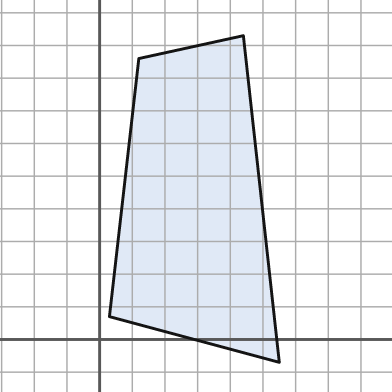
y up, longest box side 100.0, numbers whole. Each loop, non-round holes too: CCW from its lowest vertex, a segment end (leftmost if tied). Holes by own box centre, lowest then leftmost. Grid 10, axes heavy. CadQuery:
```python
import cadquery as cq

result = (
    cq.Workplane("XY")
    .moveTo(55.0, -7.0)
    .lineTo(44.0, 93.0)
    .lineTo(12.0, 86.0)
    .lineTo(3.0, 7.0)
    .close()
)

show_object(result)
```